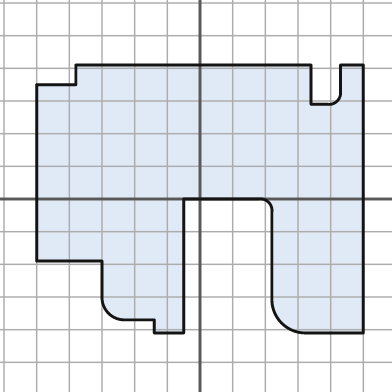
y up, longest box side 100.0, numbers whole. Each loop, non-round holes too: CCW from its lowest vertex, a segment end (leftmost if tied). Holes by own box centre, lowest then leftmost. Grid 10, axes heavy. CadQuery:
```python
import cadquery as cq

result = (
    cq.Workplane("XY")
    .moveTo(-14.0, -41.0)
    .lineTo(-5.0, -41.0)
    .lineTo(-5.0, 0.0)
    .lineTo(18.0, 0.0)
    .threePointArc((21.0, -1.0), (22.0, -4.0))
    .lineTo(22.0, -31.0)
    .threePointArc((25.0, -38.0), (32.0, -41.0))
    .lineTo(50.0, -41.0)
    .lineTo(50.0, 41.0)
    .lineTo(43.0, 41.0)
    .lineTo(43.0, 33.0)
    .threePointArc((42.0, 30.0), (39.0, 29.0))
    .lineTo(34.0, 29.0)
    .lineTo(34.0, 41.0)
    .lineTo(-38.0, 41.0)
    .lineTo(-38.0, 35.0)
    .lineTo(-50.0, 35.0)
    .lineTo(-50.0, -19.0)
    .lineTo(-30.0, -19.0)
    .lineTo(-30.0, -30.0)
    .threePointArc((-28.0, -35.0), (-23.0, -37.0))
    .lineTo(-14.0, -37.0)
    .close()
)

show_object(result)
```